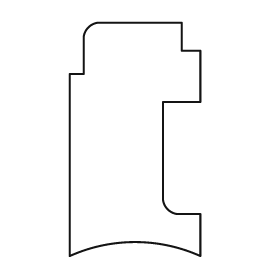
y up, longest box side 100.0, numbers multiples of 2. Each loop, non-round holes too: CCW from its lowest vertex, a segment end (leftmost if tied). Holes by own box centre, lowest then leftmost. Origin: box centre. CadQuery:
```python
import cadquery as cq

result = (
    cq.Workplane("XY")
    .moveTo(-28.0, -50.0)
    .threePointArc((0.0, -44.0), (28.0, -50.0))
    .lineTo(28.0, -32.0)
    .lineTo(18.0, -32.0)
    .threePointArc((14.0, -30.0), (12.0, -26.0))
    .lineTo(12.0, 16.0)
    .lineTo(28.0, 16.0)
    .lineTo(28.0, 38.0)
    .lineTo(20.0, 38.0)
    .lineTo(20.0, 50.0)
    .lineTo(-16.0, 50.0)
    .threePointArc((-20.0, 48.0), (-22.0, 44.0))
    .lineTo(-22.0, 28.0)
    .lineTo(-28.0, 28.0)
    .close()
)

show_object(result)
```